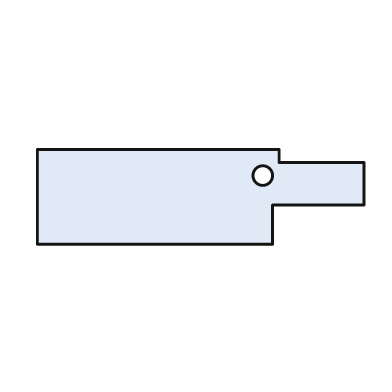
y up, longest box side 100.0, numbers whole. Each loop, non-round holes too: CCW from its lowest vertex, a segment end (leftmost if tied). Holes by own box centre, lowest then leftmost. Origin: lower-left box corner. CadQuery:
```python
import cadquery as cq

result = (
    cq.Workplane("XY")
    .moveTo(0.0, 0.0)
    .lineTo(72.0, 0.0)
    .lineTo(72.0, 12.0)
    .lineTo(100.0, 12.0)
    .lineTo(100.0, 25.0)
    .lineTo(74.0, 25.0)
    .lineTo(74.0, 29.0)
    .lineTo(0.0, 29.0)
    .close()
    .moveTo(69.0, 21.0)
    .circle(3.0)
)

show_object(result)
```